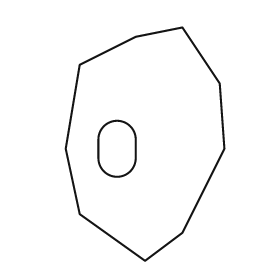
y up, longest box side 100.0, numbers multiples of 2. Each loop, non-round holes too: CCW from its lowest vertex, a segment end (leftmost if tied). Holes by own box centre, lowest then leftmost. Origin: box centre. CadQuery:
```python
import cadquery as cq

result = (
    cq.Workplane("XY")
    .moveTo(0.0, -50.0)
    .lineTo(16.0, -38.0)
    .lineTo(34.0, -2.0)
    .lineTo(32.0, 26.0)
    .lineTo(16.0, 50.0)
    .lineTo(-4.0, 46.0)
    .lineTo(-28.0, 34.0)
    .lineTo(-34.0, -2.0)
    .lineTo(-28.0, -30.0)
    .close()
    .moveTo(-20.0, -6.0)
    .threePointArc((-12.0, -14.0), (-4.0, -6.0))
    .lineTo(-4.0, 2.0)
    .threePointArc((-12.0, 10.0), (-20.0, 2.0))
    .close()
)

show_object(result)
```